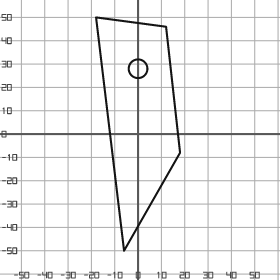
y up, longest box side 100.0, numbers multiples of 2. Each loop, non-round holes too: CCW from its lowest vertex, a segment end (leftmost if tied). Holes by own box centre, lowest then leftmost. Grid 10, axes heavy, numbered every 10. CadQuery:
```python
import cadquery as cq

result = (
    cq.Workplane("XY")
    .moveTo(-6.0, -50.0)
    .lineTo(18.0, -8.0)
    .lineTo(12.0, 46.0)
    .lineTo(-18.0, 50.0)
    .close()
    .moveTo(0.0, 28.0)
    .circle(4.0)
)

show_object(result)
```